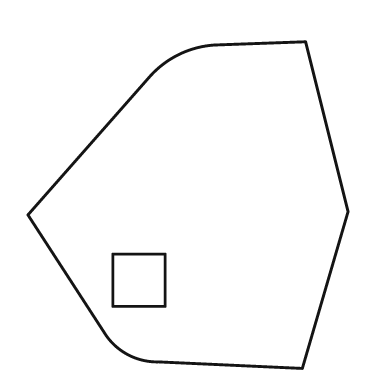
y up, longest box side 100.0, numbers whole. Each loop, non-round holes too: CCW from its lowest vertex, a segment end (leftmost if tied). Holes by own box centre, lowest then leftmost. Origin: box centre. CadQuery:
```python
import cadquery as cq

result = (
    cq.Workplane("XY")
    .moveTo(35.0, -50.0)
    .lineTo(49.0, -2.0)
    .lineTo(36.0, 50.0)
    .lineTo(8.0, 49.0)
    .threePointArc((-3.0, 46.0), (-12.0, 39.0))
    .lineTo(-49.0, -3.0)
    .lineTo(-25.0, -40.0)
    .threePointArc((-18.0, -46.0), (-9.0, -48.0))
    .close()
    .moveTo(-23.0, -31.0)
    .lineTo(-7.0, -31.0)
    .lineTo(-7.0, -15.0)
    .lineTo(-23.0, -15.0)
    .close()
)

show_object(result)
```